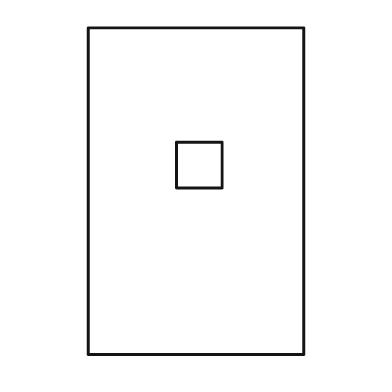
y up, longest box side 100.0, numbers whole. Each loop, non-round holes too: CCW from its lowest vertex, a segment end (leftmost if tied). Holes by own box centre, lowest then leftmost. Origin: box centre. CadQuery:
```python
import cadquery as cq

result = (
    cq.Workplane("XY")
    .moveTo(-33.0, -50.0)
    .lineTo(33.0, -50.0)
    .lineTo(33.0, 50.0)
    .lineTo(-33.0, 50.0)
    .close()
    .moveTo(-6.0, 1.0)
    .lineTo(8.0, 1.0)
    .lineTo(8.0, 15.0)
    .lineTo(-6.0, 15.0)
    .close()
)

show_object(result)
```